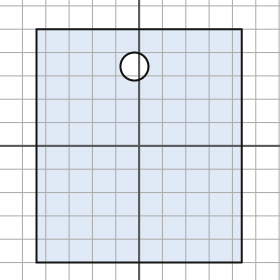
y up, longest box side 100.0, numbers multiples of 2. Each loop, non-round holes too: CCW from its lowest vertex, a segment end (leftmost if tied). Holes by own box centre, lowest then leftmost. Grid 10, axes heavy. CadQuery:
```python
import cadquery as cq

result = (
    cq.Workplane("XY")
    .moveTo(-44.0, -50.0)
    .lineTo(44.0, -50.0)
    .lineTo(44.0, 50.0)
    .lineTo(-44.0, 50.0)
    .close()
    .moveTo(-2.0, 34.0)
    .circle(6.0)
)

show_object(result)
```